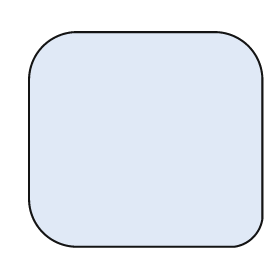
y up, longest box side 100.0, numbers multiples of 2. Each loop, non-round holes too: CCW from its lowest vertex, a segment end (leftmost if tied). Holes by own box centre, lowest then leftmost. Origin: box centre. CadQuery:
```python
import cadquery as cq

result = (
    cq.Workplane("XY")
    .moveTo(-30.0, -46.0)
    .lineTo(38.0, -46.0)
    .threePointArc((46.0, -42.0), (50.0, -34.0))
    .lineTo(50.0, 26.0)
    .threePointArc((44.0, 40.0), (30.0, 46.0))
    .lineTo(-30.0, 46.0)
    .threePointArc((-44.0, 40.0), (-50.0, 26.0))
    .lineTo(-50.0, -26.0)
    .threePointArc((-44.0, -40.0), (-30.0, -46.0))
    .close()
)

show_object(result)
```